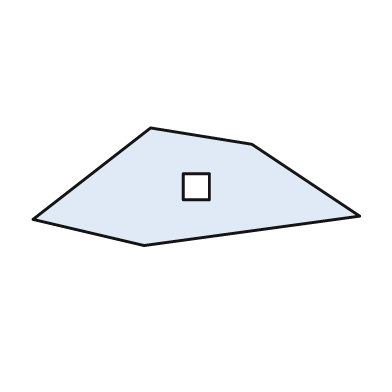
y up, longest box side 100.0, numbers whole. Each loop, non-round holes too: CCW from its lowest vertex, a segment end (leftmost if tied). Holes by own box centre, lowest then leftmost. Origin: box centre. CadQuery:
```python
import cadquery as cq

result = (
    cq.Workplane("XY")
    .moveTo(-16.0, -18.0)
    .lineTo(50.0, -9.0)
    .lineTo(17.0, 13.0)
    .lineTo(-14.0, 18.0)
    .lineTo(-50.0, -10.0)
    .close()
    .moveTo(-4.0, -4.0)
    .lineTo(4.0, -4.0)
    .lineTo(4.0, 4.0)
    .lineTo(-4.0, 4.0)
    .close()
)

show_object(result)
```